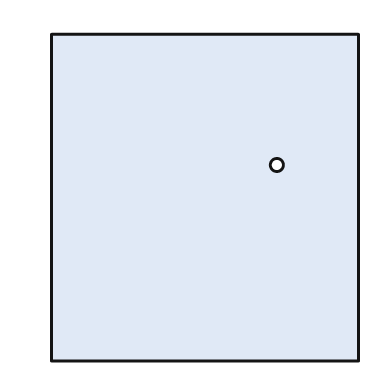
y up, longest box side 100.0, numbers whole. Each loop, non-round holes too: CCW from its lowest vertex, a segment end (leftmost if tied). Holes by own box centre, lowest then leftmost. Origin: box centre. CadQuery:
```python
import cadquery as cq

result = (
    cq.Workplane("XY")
    .moveTo(-47.0, -50.0)
    .lineTo(47.0, -50.0)
    .lineTo(47.0, 50.0)
    .lineTo(-47.0, 50.0)
    .close()
    .moveTo(22.0, 10.0)
    .circle(2.0)
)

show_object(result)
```